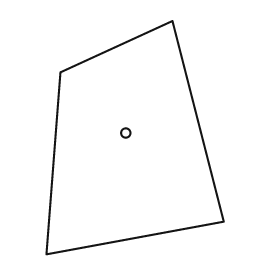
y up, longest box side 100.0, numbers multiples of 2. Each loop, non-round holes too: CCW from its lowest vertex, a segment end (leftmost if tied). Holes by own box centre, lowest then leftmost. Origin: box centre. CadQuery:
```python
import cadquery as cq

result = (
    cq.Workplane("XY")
    .moveTo(-38.0, -50.0)
    .lineTo(38.0, -36.0)
    .lineTo(16.0, 50.0)
    .lineTo(-32.0, 28.0)
    .close()
    .moveTo(-4.0, 2.0)
    .circle(2.0)
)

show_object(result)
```